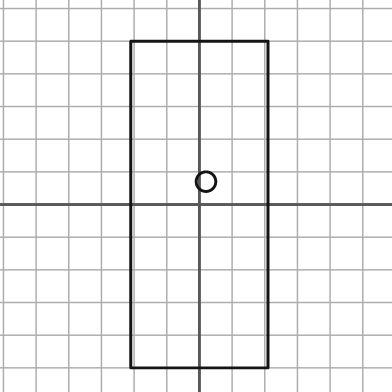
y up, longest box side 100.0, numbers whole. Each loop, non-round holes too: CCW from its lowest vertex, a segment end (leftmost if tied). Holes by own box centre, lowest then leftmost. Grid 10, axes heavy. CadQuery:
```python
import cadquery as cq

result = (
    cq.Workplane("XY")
    .moveTo(-21.0, -50.0)
    .lineTo(21.0, -50.0)
    .lineTo(21.0, 50.0)
    .lineTo(-21.0, 50.0)
    .close()
    .moveTo(2.0, 7.0)
    .circle(3.0)
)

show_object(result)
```